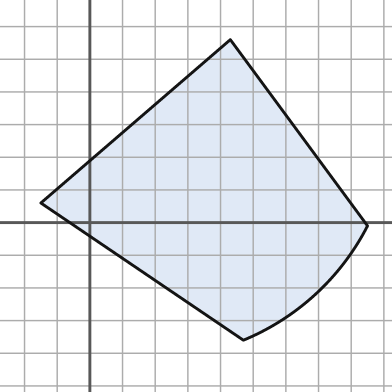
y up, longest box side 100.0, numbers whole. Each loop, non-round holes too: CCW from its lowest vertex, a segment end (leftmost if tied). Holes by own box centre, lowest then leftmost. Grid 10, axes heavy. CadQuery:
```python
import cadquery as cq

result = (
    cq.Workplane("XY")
    .moveTo(47.0, -36.0)
    .threePointArc((69.0, -22.0), (85.0, -1.0))
    .lineTo(43.0, 56.0)
    .lineTo(-15.0, 6.0)
    .close()
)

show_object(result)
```